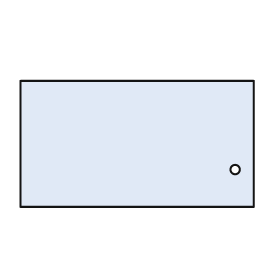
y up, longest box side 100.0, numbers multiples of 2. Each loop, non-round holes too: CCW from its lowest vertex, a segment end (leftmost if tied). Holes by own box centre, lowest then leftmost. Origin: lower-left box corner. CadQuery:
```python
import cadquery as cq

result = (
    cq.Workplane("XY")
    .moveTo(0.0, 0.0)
    .lineTo(100.0, 0.0)
    .lineTo(100.0, 54.0)
    .lineTo(0.0, 54.0)
    .close()
    .moveTo(92.0, 16.0)
    .circle(2.0)
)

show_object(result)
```